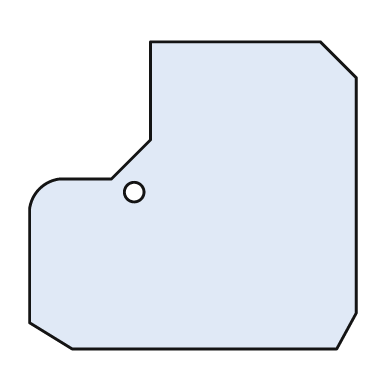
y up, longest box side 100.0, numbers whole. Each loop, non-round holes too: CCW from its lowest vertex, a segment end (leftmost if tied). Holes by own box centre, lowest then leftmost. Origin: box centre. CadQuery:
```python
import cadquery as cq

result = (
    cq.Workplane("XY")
    .moveTo(-37.0, -47.0)
    .lineTo(44.0, -47.0)
    .lineTo(50.0, -36.0)
    .lineTo(50.0, 36.0)
    .lineTo(39.0, 47.0)
    .lineTo(-13.0, 47.0)
    .lineTo(-13.0, 17.0)
    .lineTo(-25.0, 5.0)
    .lineTo(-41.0, 5.0)
    .threePointArc((-47.0, 2.0), (-50.0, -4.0))
    .lineTo(-50.0, -39.0)
    .close()
    .moveTo(-18.0, 1.0)
    .circle(3.0)
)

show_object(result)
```